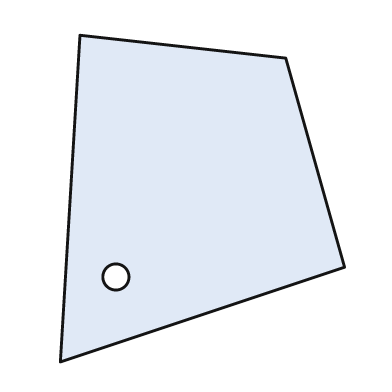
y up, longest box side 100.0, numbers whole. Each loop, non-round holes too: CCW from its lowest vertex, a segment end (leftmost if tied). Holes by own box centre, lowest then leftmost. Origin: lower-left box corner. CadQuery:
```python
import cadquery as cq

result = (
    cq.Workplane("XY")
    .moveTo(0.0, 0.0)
    .lineTo(87.0, 29.0)
    .lineTo(69.0, 93.0)
    .lineTo(6.0, 100.0)
    .close()
    .moveTo(17.0, 26.0)
    .circle(4.0)
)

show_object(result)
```